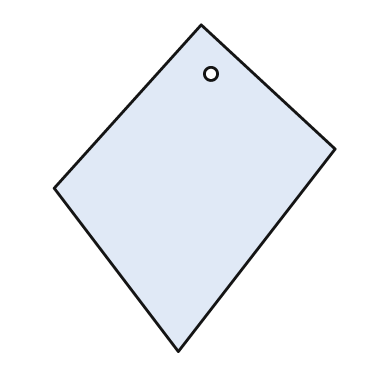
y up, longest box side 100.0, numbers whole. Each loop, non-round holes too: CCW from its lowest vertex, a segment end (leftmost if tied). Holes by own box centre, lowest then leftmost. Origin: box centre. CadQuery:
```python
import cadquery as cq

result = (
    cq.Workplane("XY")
    .moveTo(-5.0, -50.0)
    .lineTo(43.0, 12.0)
    .lineTo(2.0, 50.0)
    .lineTo(-43.0, 0.0)
    .close()
    .moveTo(5.0, 35.0)
    .circle(2.0)
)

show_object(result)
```